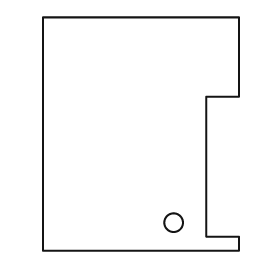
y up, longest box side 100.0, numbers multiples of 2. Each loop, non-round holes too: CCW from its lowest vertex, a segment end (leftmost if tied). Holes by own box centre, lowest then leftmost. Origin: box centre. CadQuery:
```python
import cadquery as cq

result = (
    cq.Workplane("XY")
    .moveTo(-42.0, -50.0)
    .lineTo(42.0, -50.0)
    .lineTo(42.0, -44.0)
    .lineTo(28.0, -44.0)
    .lineTo(28.0, 16.0)
    .lineTo(42.0, 16.0)
    .lineTo(42.0, 50.0)
    .lineTo(-42.0, 50.0)
    .close()
    .moveTo(14.0, -38.0)
    .circle(4.0)
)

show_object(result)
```